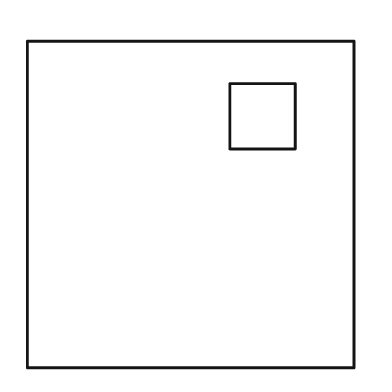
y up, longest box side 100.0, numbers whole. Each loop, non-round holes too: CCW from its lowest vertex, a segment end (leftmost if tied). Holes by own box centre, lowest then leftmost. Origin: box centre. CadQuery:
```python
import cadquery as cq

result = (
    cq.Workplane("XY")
    .moveTo(-50.0, -50.0)
    .lineTo(50.0, -50.0)
    .lineTo(50.0, 50.0)
    .lineTo(-50.0, 50.0)
    .close()
    .moveTo(12.0, 17.0)
    .lineTo(32.0, 17.0)
    .lineTo(32.0, 37.0)
    .lineTo(12.0, 37.0)
    .close()
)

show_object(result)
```